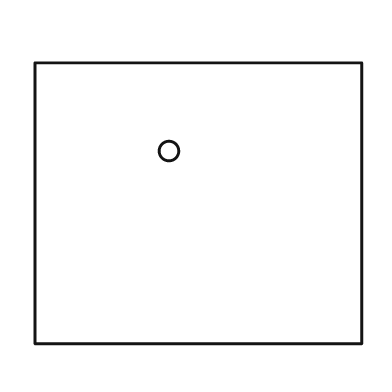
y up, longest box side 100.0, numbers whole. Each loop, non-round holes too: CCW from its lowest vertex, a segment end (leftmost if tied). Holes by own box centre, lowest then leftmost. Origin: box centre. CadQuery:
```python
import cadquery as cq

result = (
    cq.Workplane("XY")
    .moveTo(-50.0, -43.0)
    .lineTo(50.0, -43.0)
    .lineTo(50.0, 43.0)
    .lineTo(-50.0, 43.0)
    .close()
    .moveTo(-9.0, 16.0)
    .circle(3.0)
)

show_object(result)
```